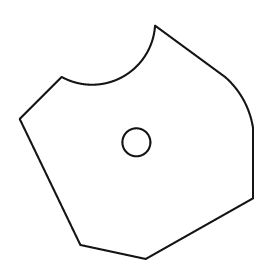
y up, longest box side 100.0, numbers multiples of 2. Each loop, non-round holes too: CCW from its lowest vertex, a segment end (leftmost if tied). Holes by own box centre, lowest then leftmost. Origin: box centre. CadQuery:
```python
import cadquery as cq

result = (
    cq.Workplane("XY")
    .moveTo(4.0, -50.0)
    .lineTo(50.0, -24.0)
    .lineTo(50.0, 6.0)
    .threePointArc((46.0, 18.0), (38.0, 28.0))
    .lineTo(8.0, 50.0)
    .threePointArc((-6.0, 28.0), (-32.0, 28.0))
    .lineTo(-50.0, 10.0)
    .lineTo(-24.0, -44.0)
    .close()
    .moveTo(0.0, 0.0)
    .circle(6.0)
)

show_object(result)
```